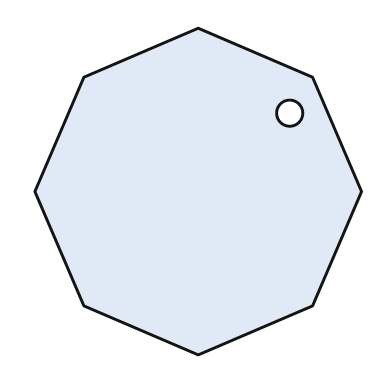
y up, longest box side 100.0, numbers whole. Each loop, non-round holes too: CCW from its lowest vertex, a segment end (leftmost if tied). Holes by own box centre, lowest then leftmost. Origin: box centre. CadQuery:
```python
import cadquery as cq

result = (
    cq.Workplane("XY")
    .moveTo(0.0, -50.0)
    .lineTo(35.0, -35.0)
    .lineTo(50.0, 0.0)
    .lineTo(35.0, 35.0)
    .lineTo(0.0, 50.0)
    .lineTo(-35.0, 35.0)
    .lineTo(-50.0, 0.0)
    .lineTo(-35.0, -35.0)
    .close()
    .moveTo(28.0, 24.0)
    .circle(4.0)
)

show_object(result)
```